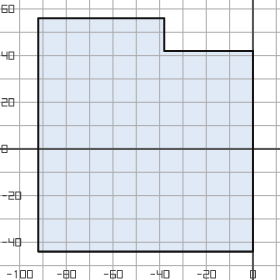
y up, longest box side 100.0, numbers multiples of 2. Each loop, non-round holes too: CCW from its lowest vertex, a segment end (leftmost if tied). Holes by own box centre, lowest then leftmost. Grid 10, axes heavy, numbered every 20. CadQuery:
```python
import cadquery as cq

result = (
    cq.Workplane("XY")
    .moveTo(-92.0, -44.0)
    .lineTo(0.0, -44.0)
    .lineTo(0.0, 42.0)
    .lineTo(-38.0, 42.0)
    .lineTo(-38.0, 56.0)
    .lineTo(-92.0, 56.0)
    .close()
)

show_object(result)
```